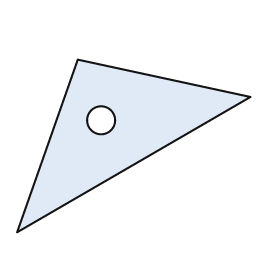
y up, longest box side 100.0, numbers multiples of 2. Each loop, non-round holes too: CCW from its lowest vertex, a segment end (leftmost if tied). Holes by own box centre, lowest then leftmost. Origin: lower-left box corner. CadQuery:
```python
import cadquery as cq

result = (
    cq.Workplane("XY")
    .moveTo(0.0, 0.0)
    .lineTo(100.0, 58.0)
    .lineTo(26.0, 74.0)
    .close()
    .moveTo(36.0, 48.0)
    .circle(6.0)
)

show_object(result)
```